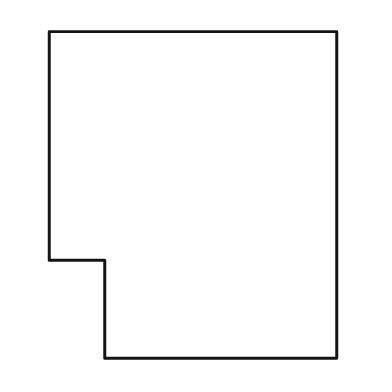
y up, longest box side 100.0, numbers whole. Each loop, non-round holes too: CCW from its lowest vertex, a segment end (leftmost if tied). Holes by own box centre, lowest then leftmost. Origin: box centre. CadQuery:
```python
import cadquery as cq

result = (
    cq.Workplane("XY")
    .moveTo(-27.0, -50.0)
    .lineTo(44.0, -50.0)
    .lineTo(44.0, 50.0)
    .lineTo(-44.0, 50.0)
    .lineTo(-44.0, -20.0)
    .lineTo(-27.0, -20.0)
    .close()
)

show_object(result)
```